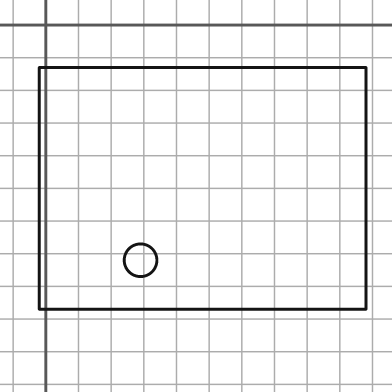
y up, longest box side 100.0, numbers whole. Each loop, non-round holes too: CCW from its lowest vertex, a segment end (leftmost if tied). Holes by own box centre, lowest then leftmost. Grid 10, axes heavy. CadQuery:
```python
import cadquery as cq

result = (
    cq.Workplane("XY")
    .moveTo(-2.0, -87.0)
    .lineTo(98.0, -87.0)
    .lineTo(98.0, -13.0)
    .lineTo(-2.0, -13.0)
    .close()
    .moveTo(29.0, -72.0)
    .circle(5.0)
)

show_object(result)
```